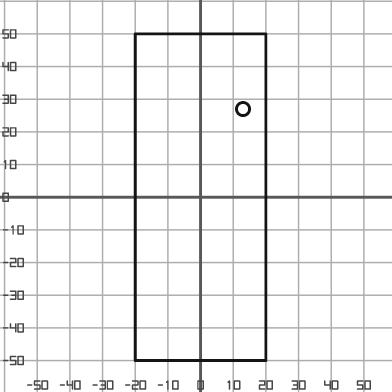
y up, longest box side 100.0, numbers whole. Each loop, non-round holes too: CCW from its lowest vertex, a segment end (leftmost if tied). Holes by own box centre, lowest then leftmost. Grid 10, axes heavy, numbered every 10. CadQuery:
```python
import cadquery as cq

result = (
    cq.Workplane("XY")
    .moveTo(-20.0, -50.0)
    .lineTo(20.0, -50.0)
    .lineTo(20.0, 50.0)
    .lineTo(-20.0, 50.0)
    .close()
    .moveTo(13.0, 27.0)
    .circle(2.0)
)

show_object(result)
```